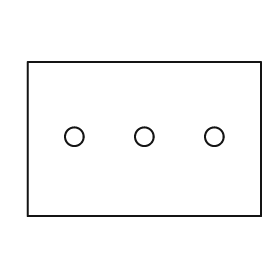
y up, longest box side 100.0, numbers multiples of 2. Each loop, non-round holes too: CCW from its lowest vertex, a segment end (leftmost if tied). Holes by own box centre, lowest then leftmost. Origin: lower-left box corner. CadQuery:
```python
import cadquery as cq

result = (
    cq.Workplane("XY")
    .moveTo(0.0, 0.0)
    .lineTo(100.0, 0.0)
    .lineTo(100.0, 66.0)
    .lineTo(0.0, 66.0)
    .close()
    .moveTo(20.0, 34.0)
    .circle(4.0)
    .moveTo(50.0, 34.0)
    .circle(4.0)
    .moveTo(80.0, 34.0)
    .circle(4.0)
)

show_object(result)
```